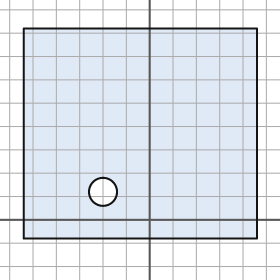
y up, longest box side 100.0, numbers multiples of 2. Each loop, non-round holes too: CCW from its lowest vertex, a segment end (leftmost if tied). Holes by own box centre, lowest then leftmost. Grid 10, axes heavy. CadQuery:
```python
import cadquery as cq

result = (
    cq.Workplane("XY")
    .moveTo(-54.0, -8.0)
    .lineTo(46.0, -8.0)
    .lineTo(46.0, 82.0)
    .lineTo(-54.0, 82.0)
    .close()
    .moveTo(-20.0, 12.0)
    .circle(6.0)
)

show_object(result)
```